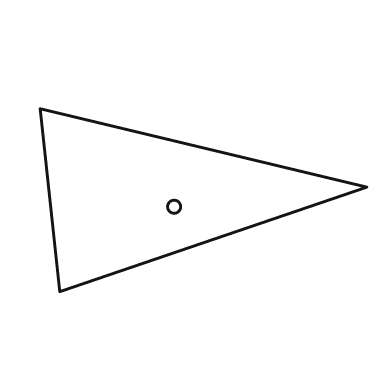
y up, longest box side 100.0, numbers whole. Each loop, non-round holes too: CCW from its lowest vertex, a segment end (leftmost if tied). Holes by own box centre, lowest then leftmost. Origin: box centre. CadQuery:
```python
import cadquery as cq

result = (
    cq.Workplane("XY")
    .moveTo(-44.0, -28.0)
    .lineTo(50.0, 4.0)
    .lineTo(-50.0, 28.0)
    .close()
    .moveTo(-9.0, -2.0)
    .circle(2.0)
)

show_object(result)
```